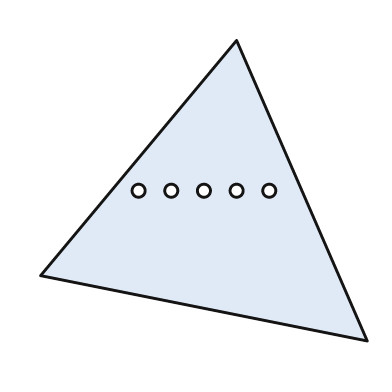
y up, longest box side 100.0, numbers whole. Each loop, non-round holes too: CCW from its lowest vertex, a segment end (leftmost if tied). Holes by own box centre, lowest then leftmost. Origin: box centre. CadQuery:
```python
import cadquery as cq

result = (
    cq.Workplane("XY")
    .moveTo(50.0, -46.0)
    .lineTo(10.0, 46.0)
    .lineTo(-50.0, -26.0)
    .close()
    .moveTo(-20.0, 0.0)
    .circle(2.0)
    .moveTo(-10.0, 0.0)
    .circle(2.0)
    .moveTo(0.0, 0.0)
    .circle(2.0)
    .moveTo(10.0, 0.0)
    .circle(2.0)
    .moveTo(20.0, 0.0)
    .circle(2.0)
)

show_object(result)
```